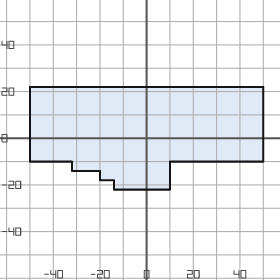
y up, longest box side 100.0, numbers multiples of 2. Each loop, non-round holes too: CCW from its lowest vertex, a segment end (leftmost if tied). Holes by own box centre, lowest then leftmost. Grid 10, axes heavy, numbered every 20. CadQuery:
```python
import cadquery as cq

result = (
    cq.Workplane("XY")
    .moveTo(-14.0, -22.0)
    .lineTo(10.0, -22.0)
    .lineTo(10.0, -10.0)
    .lineTo(50.0, -10.0)
    .lineTo(50.0, 22.0)
    .lineTo(-50.0, 22.0)
    .lineTo(-50.0, -10.0)
    .lineTo(-32.0, -10.0)
    .lineTo(-32.0, -14.0)
    .lineTo(-20.0, -14.0)
    .lineTo(-20.0, -18.0)
    .lineTo(-14.0, -18.0)
    .close()
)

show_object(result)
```